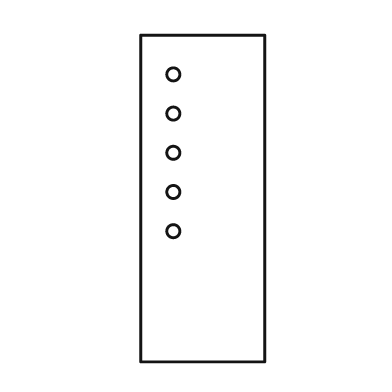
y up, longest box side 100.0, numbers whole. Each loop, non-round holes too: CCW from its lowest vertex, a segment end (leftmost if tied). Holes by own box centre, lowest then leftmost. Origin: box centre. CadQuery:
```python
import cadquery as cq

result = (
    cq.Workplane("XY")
    .moveTo(-19.0, -50.0)
    .lineTo(19.0, -50.0)
    .lineTo(19.0, 50.0)
    .lineTo(-19.0, 50.0)
    .close()
    .moveTo(-9.0, -10.0)
    .circle(2.0)
    .moveTo(-9.0, 2.0)
    .circle(2.0)
    .moveTo(-9.0, 14.0)
    .circle(2.0)
    .moveTo(-9.0, 26.0)
    .circle(2.0)
    .moveTo(-9.0, 38.0)
    .circle(2.0)
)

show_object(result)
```